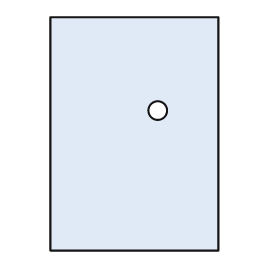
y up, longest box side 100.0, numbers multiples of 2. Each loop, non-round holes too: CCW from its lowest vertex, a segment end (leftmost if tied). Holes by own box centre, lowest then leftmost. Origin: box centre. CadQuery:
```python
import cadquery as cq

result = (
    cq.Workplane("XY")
    .moveTo(-36.0, -50.0)
    .lineTo(36.0, -50.0)
    .lineTo(36.0, 50.0)
    .lineTo(-36.0, 50.0)
    .close()
    .moveTo(10.0, 10.0)
    .circle(4.0)
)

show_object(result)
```